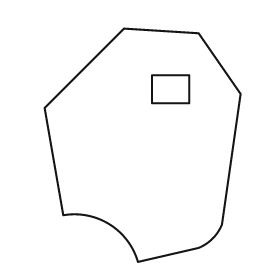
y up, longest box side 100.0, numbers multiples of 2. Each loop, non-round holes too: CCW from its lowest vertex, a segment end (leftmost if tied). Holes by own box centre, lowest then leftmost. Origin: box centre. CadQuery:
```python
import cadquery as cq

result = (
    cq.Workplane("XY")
    .moveTo(-2.0, -50.0)
    .lineTo(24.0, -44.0)
    .threePointArc((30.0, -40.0), (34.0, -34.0))
    .lineTo(42.0, 22.0)
    .lineTo(24.0, 48.0)
    .lineTo(-8.0, 50.0)
    .lineTo(-42.0, 16.0)
    .lineTo(-34.0, -30.0)
    .threePointArc((-14.0, -34.0), (-2.0, -50.0))
    .close()
    .moveTo(4.0, 18.0)
    .lineTo(20.0, 18.0)
    .lineTo(20.0, 30.0)
    .lineTo(4.0, 30.0)
    .close()
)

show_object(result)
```